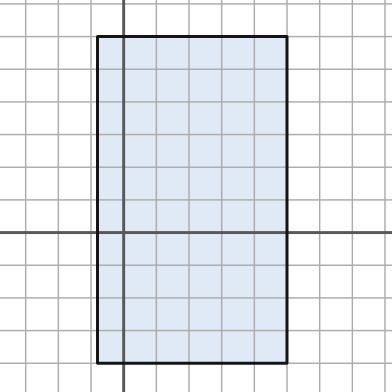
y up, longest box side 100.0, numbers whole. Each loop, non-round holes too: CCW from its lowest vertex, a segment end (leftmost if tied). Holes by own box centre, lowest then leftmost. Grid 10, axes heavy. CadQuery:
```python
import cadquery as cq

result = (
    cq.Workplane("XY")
    .moveTo(-8.0, -40.0)
    .lineTo(50.0, -40.0)
    .lineTo(50.0, 60.0)
    .lineTo(-8.0, 60.0)
    .close()
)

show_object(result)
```